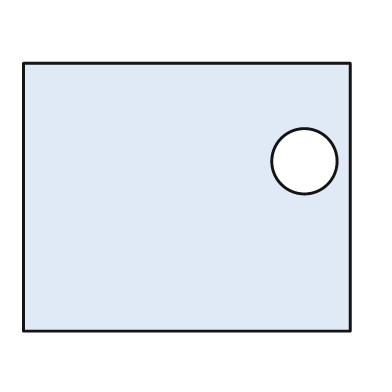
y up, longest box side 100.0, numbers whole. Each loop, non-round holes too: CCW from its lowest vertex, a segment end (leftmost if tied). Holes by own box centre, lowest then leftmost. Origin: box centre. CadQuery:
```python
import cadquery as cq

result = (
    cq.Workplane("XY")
    .moveTo(-50.0, -41.0)
    .lineTo(50.0, -41.0)
    .lineTo(50.0, 41.0)
    .lineTo(-50.0, 41.0)
    .close()
    .moveTo(36.0, 11.0)
    .circle(10.0)
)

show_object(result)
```